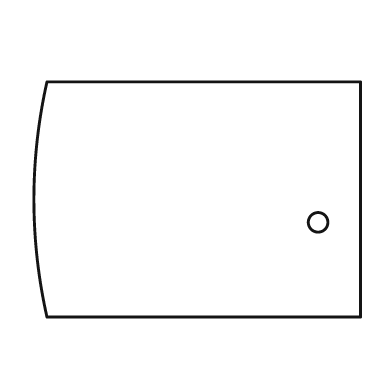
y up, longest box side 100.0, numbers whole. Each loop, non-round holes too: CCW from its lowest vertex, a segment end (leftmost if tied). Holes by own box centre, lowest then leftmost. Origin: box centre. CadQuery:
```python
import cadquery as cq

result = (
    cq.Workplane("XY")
    .moveTo(-46.0, -36.0)
    .lineTo(50.0, -36.0)
    .lineTo(50.0, 36.0)
    .lineTo(-46.0, 36.0)
    .threePointArc((-50.0, 0.0), (-46.0, -36.0))
    .close()
    .moveTo(37.0, -7.0)
    .circle(3.0)
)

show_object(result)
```